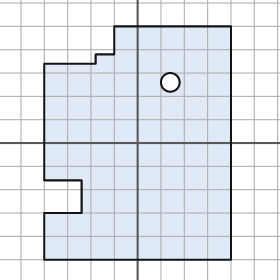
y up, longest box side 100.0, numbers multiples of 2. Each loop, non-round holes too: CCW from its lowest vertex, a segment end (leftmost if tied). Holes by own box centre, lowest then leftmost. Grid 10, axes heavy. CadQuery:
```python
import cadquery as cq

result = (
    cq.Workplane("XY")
    .moveTo(-40.0, -50.0)
    .lineTo(40.0, -50.0)
    .lineTo(40.0, 50.0)
    .lineTo(-10.0, 50.0)
    .lineTo(-10.0, 38.0)
    .lineTo(-18.0, 38.0)
    .lineTo(-18.0, 34.0)
    .lineTo(-40.0, 34.0)
    .lineTo(-40.0, -16.0)
    .lineTo(-24.0, -16.0)
    .lineTo(-24.0, -30.0)
    .lineTo(-40.0, -30.0)
    .close()
    .moveTo(14.0, 26.0)
    .circle(4.0)
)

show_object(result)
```